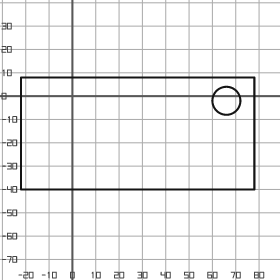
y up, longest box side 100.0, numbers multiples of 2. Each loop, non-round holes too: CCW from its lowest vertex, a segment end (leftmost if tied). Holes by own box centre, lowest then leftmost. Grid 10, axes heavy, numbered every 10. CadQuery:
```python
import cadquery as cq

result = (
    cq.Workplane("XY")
    .moveTo(-22.0, -40.0)
    .lineTo(78.0, -40.0)
    .lineTo(78.0, 8.0)
    .lineTo(-22.0, 8.0)
    .close()
    .moveTo(66.0, -2.0)
    .circle(6.0)
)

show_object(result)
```